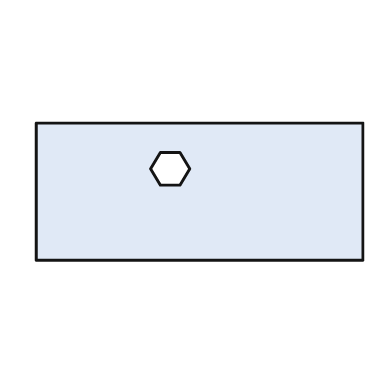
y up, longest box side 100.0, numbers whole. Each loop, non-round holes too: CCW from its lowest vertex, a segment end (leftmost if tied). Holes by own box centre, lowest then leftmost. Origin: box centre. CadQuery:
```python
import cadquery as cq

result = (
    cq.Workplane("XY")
    .moveTo(-50.0, -21.0)
    .lineTo(50.0, -21.0)
    .lineTo(50.0, 21.0)
    .lineTo(-50.0, 21.0)
    .close()
    .moveTo(-12.0, 2.0)
    .lineTo(-6.0, 2.0)
    .lineTo(-3.0, 7.0)
    .lineTo(-6.0, 12.0)
    .lineTo(-12.0, 12.0)
    .lineTo(-15.0, 7.0)
    .close()
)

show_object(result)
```